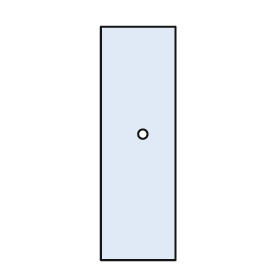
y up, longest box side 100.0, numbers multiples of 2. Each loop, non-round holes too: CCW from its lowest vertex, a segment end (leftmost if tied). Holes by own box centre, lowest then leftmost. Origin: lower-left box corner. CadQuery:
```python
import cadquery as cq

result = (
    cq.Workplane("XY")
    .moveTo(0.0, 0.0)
    .lineTo(32.0, 0.0)
    .lineTo(32.0, 100.0)
    .lineTo(0.0, 100.0)
    .close()
    .moveTo(18.0, 54.0)
    .circle(2.0)
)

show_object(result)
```